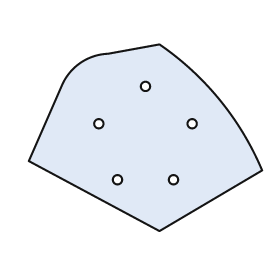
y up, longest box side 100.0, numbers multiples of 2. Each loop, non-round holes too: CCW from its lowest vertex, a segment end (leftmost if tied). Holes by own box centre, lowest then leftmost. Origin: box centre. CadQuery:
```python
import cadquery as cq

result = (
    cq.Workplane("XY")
    .moveTo(6.0, -40.0)
    .lineTo(50.0, -14.0)
    .threePointArc((32.0, 16.0), (6.0, 40.0))
    .lineTo(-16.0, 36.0)
    .threePointArc((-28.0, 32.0), (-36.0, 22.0))
    .lineTo(-50.0, -10.0)
    .close()
    .moveTo(-12.0, -18.0)
    .circle(2.0)
    .moveTo(12.0, -18.0)
    .circle(2.0)
    .moveTo(-20.0, 6.0)
    .circle(2.0)
    .moveTo(20.0, 6.0)
    .circle(2.0)
    .moveTo(0.0, 22.0)
    .circle(2.0)
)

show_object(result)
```